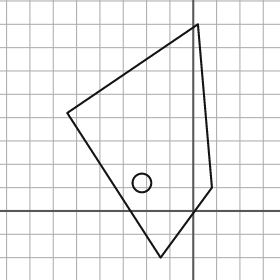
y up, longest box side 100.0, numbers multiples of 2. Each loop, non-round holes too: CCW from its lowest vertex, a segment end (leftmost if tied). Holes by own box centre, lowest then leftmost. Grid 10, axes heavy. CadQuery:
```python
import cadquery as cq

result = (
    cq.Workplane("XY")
    .moveTo(-14.0, -20.0)
    .lineTo(8.0, 10.0)
    .lineTo(2.0, 80.0)
    .lineTo(-54.0, 42.0)
    .close()
    .moveTo(-22.0, 12.0)
    .circle(4.0)
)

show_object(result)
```